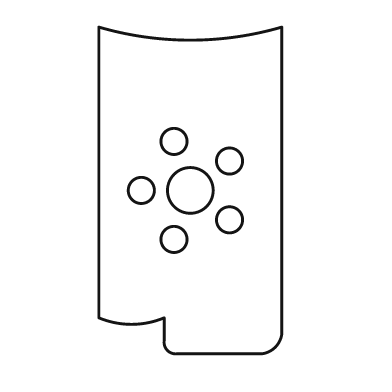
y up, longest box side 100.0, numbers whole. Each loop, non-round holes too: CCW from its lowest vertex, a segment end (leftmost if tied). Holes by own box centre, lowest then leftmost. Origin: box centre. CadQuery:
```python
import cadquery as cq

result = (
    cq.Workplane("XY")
    .moveTo(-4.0, -50.0)
    .lineTo(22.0, -50.0)
    .threePointArc((26.0, -48.0), (28.0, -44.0))
    .lineTo(28.0, 50.0)
    .threePointArc((0.0, 46.0), (-28.0, 50.0))
    .lineTo(-28.0, -39.0)
    .threePointArc((-18.0, -41.0), (-8.0, -39.0))
    .lineTo(-8.0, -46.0)
    .threePointArc((-7.0, -49.0), (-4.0, -50.0))
    .close()
    .moveTo(-5.0, -15.0)
    .circle(4.0)
    .moveTo(12.0, -9.0)
    .circle(4.0)
    .moveTo(-15.0, 0.0)
    .circle(4.0)
    .moveTo(0.0, 0.0)
    .circle(7.0)
    .moveTo(12.0, 9.0)
    .circle(4.0)
    .moveTo(-5.0, 15.0)
    .circle(4.0)
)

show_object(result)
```